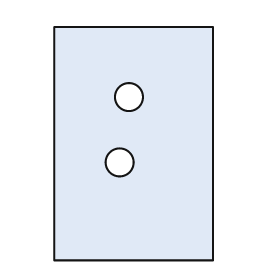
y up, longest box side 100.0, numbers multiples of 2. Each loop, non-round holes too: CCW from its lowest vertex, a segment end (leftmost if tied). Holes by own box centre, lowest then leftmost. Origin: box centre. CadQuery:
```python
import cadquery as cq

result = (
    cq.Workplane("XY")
    .moveTo(-34.0, -50.0)
    .lineTo(34.0, -50.0)
    .lineTo(34.0, 50.0)
    .lineTo(-34.0, 50.0)
    .close()
    .moveTo(-6.0, -8.0)
    .circle(6.0)
    .moveTo(-2.0, 20.0)
    .circle(6.0)
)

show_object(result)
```